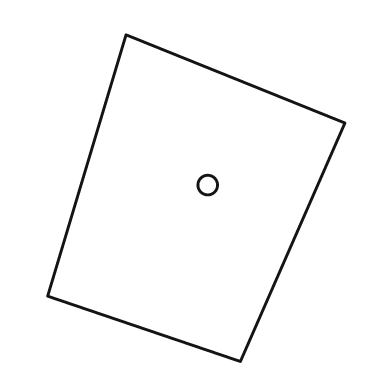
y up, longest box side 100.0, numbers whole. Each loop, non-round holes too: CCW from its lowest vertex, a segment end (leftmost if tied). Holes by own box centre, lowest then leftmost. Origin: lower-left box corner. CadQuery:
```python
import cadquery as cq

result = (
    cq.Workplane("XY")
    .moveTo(59.0, 0.0)
    .lineTo(91.0, 73.0)
    .lineTo(24.0, 100.0)
    .lineTo(0.0, 20.0)
    .close()
    .moveTo(49.0, 54.0)
    .circle(3.0)
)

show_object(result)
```